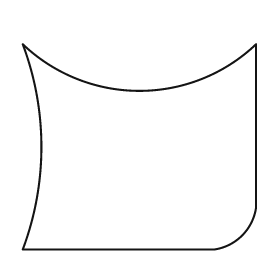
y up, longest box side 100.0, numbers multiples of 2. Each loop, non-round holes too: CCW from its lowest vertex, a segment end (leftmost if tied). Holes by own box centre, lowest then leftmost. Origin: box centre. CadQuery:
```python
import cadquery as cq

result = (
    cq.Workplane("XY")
    .moveTo(-50.0, -44.0)
    .lineTo(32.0, -44.0)
    .threePointArc((44.0, -38.0), (50.0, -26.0))
    .lineTo(50.0, 44.0)
    .threePointArc((0.0, 24.0), (-50.0, 44.0))
    .threePointArc((-42.0, 0.0), (-50.0, -44.0))
    .close()
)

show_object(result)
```